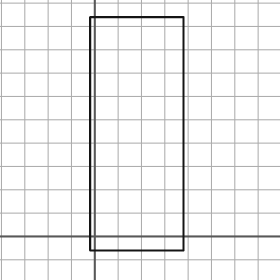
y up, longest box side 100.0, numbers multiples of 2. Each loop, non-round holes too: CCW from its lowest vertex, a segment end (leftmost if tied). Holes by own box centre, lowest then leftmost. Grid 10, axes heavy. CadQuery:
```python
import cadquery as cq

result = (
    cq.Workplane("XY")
    .moveTo(-2.0, -6.0)
    .lineTo(38.0, -6.0)
    .lineTo(38.0, 94.0)
    .lineTo(-2.0, 94.0)
    .close()
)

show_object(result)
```